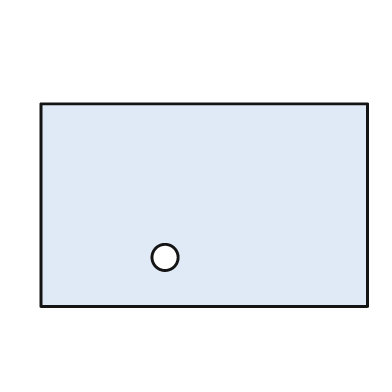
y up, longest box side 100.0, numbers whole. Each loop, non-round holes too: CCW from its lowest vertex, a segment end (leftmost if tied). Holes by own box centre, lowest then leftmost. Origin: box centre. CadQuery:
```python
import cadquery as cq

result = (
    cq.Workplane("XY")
    .moveTo(-50.0, -31.0)
    .lineTo(50.0, -31.0)
    .lineTo(50.0, 31.0)
    .lineTo(-50.0, 31.0)
    .close()
    .moveTo(-12.0, -16.0)
    .circle(4.0)
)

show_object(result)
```